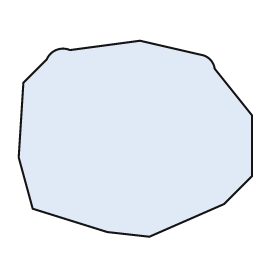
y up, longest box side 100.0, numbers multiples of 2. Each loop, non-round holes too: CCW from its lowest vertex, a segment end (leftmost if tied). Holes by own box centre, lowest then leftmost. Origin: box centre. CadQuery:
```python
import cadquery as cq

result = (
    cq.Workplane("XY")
    .moveTo(6.0, -42.0)
    .lineTo(38.0, -28.0)
    .lineTo(50.0, -16.0)
    .lineTo(50.0, 10.0)
    .lineTo(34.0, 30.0)
    .threePointArc((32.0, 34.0), (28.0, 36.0))
    .lineTo(2.0, 42.0)
    .lineTo(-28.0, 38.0)
    .threePointArc((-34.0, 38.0), (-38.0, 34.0))
    .lineTo(-48.0, 24.0)
    .lineTo(-50.0, -8.0)
    .lineTo(-44.0, -30.0)
    .lineTo(-12.0, -40.0)
    .close()
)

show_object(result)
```